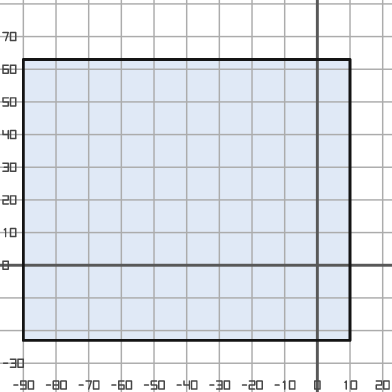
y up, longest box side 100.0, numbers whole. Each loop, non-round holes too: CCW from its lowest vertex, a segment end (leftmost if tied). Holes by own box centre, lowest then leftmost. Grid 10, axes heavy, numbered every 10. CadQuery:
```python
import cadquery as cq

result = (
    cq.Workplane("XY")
    .moveTo(-90.0, -23.0)
    .lineTo(10.0, -23.0)
    .lineTo(10.0, 63.0)
    .lineTo(-90.0, 63.0)
    .close()
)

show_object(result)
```